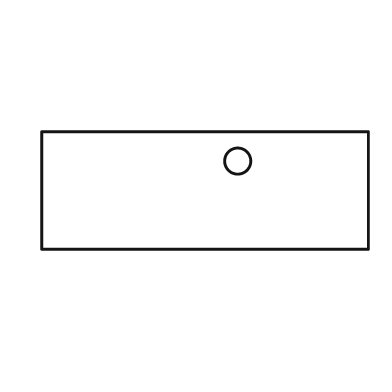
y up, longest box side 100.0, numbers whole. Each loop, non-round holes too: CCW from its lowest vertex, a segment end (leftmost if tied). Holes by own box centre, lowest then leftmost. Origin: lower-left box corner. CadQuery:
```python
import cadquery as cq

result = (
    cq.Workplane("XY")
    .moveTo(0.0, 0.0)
    .lineTo(100.0, 0.0)
    .lineTo(100.0, 36.0)
    .lineTo(0.0, 36.0)
    .close()
    .moveTo(60.0, 27.0)
    .circle(4.0)
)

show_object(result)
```